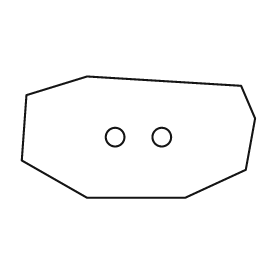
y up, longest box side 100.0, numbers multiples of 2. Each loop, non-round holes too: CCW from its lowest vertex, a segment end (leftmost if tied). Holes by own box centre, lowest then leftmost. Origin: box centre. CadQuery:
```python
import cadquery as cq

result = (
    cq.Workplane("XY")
    .moveTo(-22.0, -26.0)
    .lineTo(20.0, -26.0)
    .lineTo(46.0, -14.0)
    .lineTo(50.0, 8.0)
    .lineTo(44.0, 22.0)
    .lineTo(-22.0, 26.0)
    .lineTo(-48.0, 18.0)
    .lineTo(-50.0, -10.0)
    .close()
    .moveTo(-10.0, 0.0)
    .circle(4.0)
    .moveTo(10.0, 0.0)
    .circle(4.0)
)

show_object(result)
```